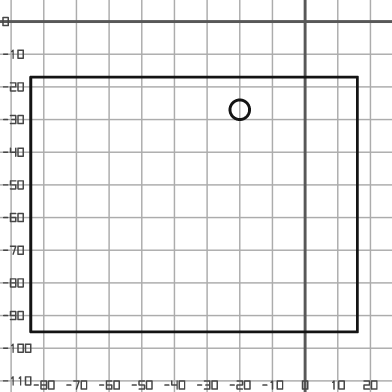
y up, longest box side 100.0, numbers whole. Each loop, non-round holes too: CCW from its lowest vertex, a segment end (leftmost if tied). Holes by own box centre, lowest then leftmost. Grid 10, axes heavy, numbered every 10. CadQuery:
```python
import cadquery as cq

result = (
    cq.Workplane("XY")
    .moveTo(-84.0, -95.0)
    .lineTo(16.0, -95.0)
    .lineTo(16.0, -17.0)
    .lineTo(-84.0, -17.0)
    .close()
    .moveTo(-20.0, -27.0)
    .circle(3.0)
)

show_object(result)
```